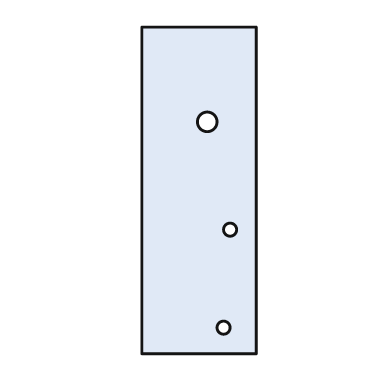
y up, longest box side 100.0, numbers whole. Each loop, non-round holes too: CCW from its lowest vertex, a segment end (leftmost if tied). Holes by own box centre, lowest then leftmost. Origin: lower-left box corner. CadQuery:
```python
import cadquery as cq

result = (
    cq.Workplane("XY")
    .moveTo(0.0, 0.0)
    .lineTo(35.0, 0.0)
    .lineTo(35.0, 100.0)
    .lineTo(0.0, 100.0)
    .close()
    .moveTo(25.0, 8.0)
    .circle(2.0)
    .moveTo(27.0, 38.0)
    .circle(2.0)
    .moveTo(20.0, 71.0)
    .circle(3.0)
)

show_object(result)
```